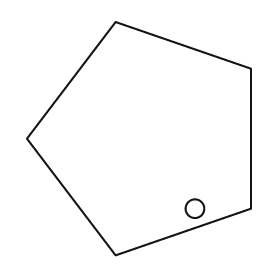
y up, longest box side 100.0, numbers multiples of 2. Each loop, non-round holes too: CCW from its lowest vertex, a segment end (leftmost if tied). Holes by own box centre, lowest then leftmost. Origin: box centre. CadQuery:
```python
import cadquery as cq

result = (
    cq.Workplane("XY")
    .moveTo(-10.0, -50.0)
    .lineTo(48.0, -30.0)
    .lineTo(48.0, 30.0)
    .lineTo(-10.0, 50.0)
    .lineTo(-48.0, 0.0)
    .close()
    .moveTo(24.0, -30.0)
    .circle(4.0)
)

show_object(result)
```